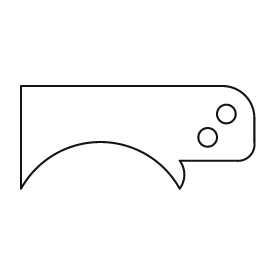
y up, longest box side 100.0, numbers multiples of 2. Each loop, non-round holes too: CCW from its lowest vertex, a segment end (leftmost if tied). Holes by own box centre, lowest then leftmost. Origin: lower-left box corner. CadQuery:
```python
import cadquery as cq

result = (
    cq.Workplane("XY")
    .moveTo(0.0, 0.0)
    .threePointArc((34.0, 20.0), (68.0, 0.0))
    .threePointArc((70.0, 6.0), (68.0, 12.0))
    .lineTo(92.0, 12.0)
    .threePointArc((98.0, 14.0), (100.0, 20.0))
    .lineTo(100.0, 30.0)
    .threePointArc((96.0, 40.0), (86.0, 44.0))
    .lineTo(0.0, 44.0)
    .close()
    .moveTo(80.0, 22.0)
    .circle(4.0)
    .moveTo(88.0, 32.0)
    .circle(4.0)
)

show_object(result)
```